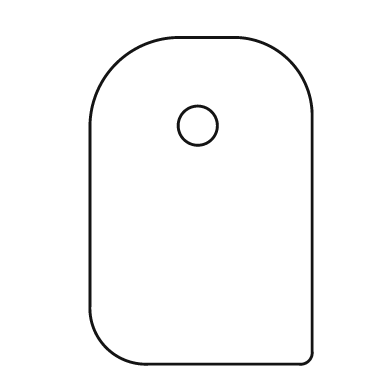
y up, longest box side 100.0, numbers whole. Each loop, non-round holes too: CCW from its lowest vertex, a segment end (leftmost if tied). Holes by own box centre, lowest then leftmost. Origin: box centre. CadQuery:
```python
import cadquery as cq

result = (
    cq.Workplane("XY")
    .moveTo(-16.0, -50.0)
    .lineTo(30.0, -50.0)
    .threePointArc((33.0, -49.0), (34.0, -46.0))
    .lineTo(34.0, 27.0)
    .threePointArc((27.0, 43.0), (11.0, 50.0))
    .lineTo(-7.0, 50.0)
    .threePointArc((-26.0, 42.0), (-34.0, 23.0))
    .lineTo(-34.0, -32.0)
    .threePointArc((-29.0, -45.0), (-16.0, -50.0))
    .close()
    .moveTo(-1.0, 23.0)
    .circle(6.0)
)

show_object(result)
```